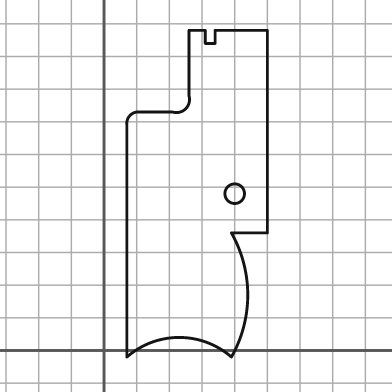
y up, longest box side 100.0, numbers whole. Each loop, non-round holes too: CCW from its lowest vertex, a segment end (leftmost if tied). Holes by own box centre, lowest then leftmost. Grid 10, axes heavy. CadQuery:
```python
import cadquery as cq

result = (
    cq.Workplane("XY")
    .moveTo(7.0, -2.0)
    .threePointArc((23.0, 4.0), (39.0, -2.0))
    .threePointArc((44.0, 17.0), (39.0, 36.0))
    .lineTo(50.0, 36.0)
    .lineTo(50.0, 98.0)
    .lineTo(34.0, 98.0)
    .lineTo(34.0, 94.0)
    .lineTo(31.0, 94.0)
    .lineTo(31.0, 98.0)
    .lineTo(26.0, 98.0)
    .lineTo(26.0, 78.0)
    .threePointArc((25.0, 74.0), (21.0, 73.0))
    .lineTo(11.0, 73.0)
    .threePointArc((8.0, 72.0), (7.0, 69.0))
    .close()
    .moveTo(40.0, 48.0)
    .circle(3.0)
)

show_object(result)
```